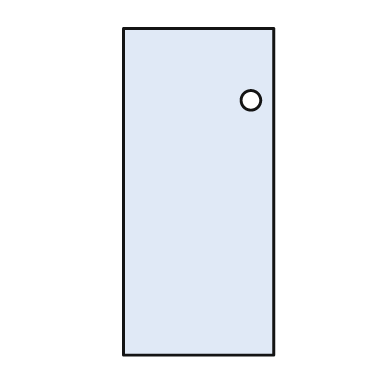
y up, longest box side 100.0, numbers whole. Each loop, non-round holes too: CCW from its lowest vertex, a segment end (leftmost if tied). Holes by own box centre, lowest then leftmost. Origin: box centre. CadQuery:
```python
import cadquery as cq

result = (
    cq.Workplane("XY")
    .moveTo(-23.0, -50.0)
    .lineTo(23.0, -50.0)
    .lineTo(23.0, 50.0)
    .lineTo(-23.0, 50.0)
    .close()
    .moveTo(16.0, 28.0)
    .circle(3.0)
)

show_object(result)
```